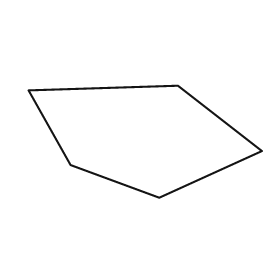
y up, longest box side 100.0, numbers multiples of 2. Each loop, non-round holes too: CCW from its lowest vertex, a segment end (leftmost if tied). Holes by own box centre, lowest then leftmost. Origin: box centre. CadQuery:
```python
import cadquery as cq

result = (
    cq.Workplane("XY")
    .moveTo(6.0, -24.0)
    .lineTo(50.0, -4.0)
    .lineTo(14.0, 24.0)
    .lineTo(-50.0, 22.0)
    .lineTo(-32.0, -10.0)
    .close()
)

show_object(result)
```